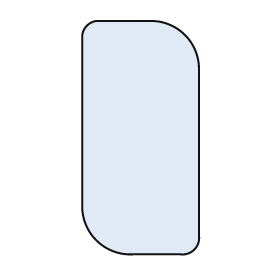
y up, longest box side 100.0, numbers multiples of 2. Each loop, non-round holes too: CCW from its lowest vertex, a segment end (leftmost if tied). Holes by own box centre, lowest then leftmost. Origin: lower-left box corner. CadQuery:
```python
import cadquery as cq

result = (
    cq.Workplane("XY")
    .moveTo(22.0, 0.0)
    .lineTo(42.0, 0.0)
    .threePointArc((48.0, 2.0), (50.0, 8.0))
    .lineTo(50.0, 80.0)
    .threePointArc((44.0, 94.0), (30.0, 100.0))
    .lineTo(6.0, 100.0)
    .threePointArc((2.0, 98.0), (0.0, 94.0))
    .lineTo(0.0, 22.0)
    .threePointArc((6.0, 6.0), (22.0, 0.0))
    .close()
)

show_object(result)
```